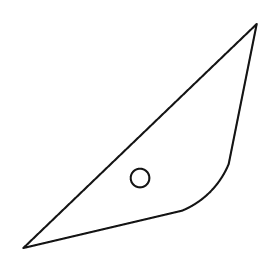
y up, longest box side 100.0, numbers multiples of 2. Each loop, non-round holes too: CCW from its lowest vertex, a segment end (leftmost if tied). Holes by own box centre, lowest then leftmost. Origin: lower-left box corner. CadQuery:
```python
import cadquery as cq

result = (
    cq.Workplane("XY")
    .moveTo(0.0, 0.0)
    .lineTo(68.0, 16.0)
    .threePointArc((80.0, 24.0), (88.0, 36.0))
    .lineTo(100.0, 96.0)
    .close()
    .moveTo(50.0, 30.0)
    .circle(4.0)
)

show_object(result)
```